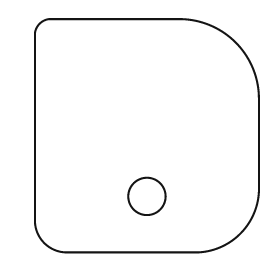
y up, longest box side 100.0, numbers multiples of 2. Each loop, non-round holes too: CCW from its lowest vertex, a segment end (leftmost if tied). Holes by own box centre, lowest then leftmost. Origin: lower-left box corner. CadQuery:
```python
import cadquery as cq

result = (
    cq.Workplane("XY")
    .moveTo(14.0, 0.0)
    .lineTo(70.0, 0.0)
    .threePointArc((88.0, 8.0), (96.0, 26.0))
    .lineTo(96.0, 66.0)
    .threePointArc((86.0, 90.0), (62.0, 100.0))
    .lineTo(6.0, 100.0)
    .threePointArc((2.0, 98.0), (0.0, 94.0))
    .lineTo(0.0, 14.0)
    .threePointArc((4.0, 4.0), (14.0, 0.0))
    .close()
    .moveTo(48.0, 24.0)
    .circle(8.0)
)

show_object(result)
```